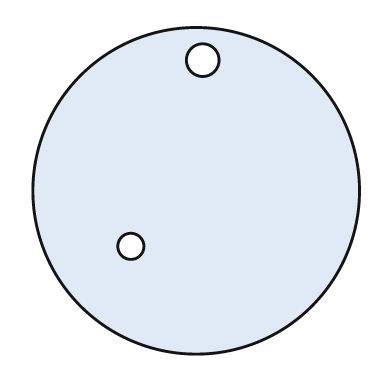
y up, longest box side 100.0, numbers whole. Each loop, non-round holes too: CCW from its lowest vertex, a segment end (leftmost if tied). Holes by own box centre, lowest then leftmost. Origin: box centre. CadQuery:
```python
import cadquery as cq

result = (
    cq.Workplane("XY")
    .moveTo(0.0, 0.0)
    .circle(50.0)
    .moveTo(-20.0, -17.0)
    .circle(4.0)
    .moveTo(2.0, 40.0)
    .circle(5.0)
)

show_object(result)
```